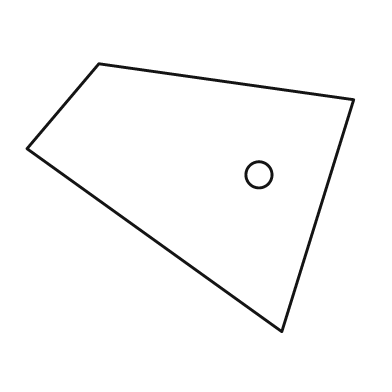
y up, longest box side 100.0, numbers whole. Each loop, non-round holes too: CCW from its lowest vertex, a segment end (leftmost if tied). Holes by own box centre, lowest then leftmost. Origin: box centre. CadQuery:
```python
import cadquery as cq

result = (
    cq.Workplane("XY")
    .moveTo(28.0, -41.0)
    .lineTo(50.0, 30.0)
    .lineTo(-28.0, 41.0)
    .lineTo(-50.0, 15.0)
    .close()
    .moveTo(21.0, 7.0)
    .circle(4.0)
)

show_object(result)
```